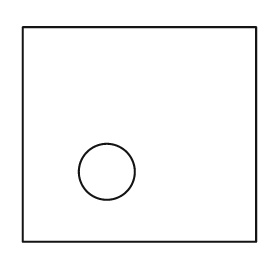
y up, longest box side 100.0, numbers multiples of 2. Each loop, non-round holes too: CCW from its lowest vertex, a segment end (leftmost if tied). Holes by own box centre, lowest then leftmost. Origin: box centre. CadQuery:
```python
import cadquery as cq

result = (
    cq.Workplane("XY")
    .moveTo(-50.0, -46.0)
    .lineTo(50.0, -46.0)
    .lineTo(50.0, 46.0)
    .lineTo(-50.0, 46.0)
    .close()
    .moveTo(-14.0, -16.0)
    .circle(12.0)
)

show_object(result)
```